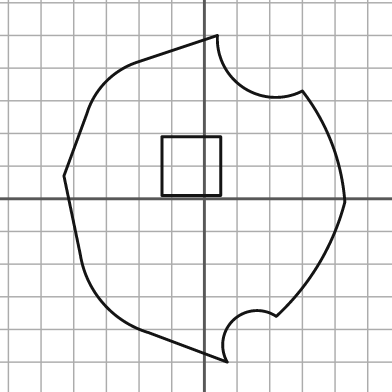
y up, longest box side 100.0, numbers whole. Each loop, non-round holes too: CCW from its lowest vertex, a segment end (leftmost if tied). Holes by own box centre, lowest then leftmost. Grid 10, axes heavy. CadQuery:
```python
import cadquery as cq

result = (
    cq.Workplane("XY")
    .moveTo(7.0, -50.0)
    .threePointArc((9.0, -37.0), (22.0, -36.0))
    .threePointArc((35.0, -20.0), (43.0, -1.0))
    .threePointArc((39.0, 17.0), (30.0, 33.0))
    .threePointArc((12.0, 34.0), (4.0, 50.0))
    .lineTo(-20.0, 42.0)
    .threePointArc((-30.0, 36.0), (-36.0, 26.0))
    .lineTo(-43.0, 7.0)
    .lineTo(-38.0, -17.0)
    .threePointArc((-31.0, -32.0), (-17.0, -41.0))
    .close()
    .moveTo(-13.0, 1.0)
    .lineTo(5.0, 1.0)
    .lineTo(5.0, 19.0)
    .lineTo(-13.0, 19.0)
    .close()
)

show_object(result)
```